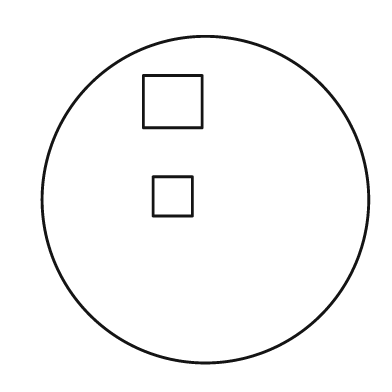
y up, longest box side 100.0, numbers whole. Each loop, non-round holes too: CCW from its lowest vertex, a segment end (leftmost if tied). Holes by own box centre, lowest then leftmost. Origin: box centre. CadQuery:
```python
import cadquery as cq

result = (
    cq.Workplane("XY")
    .moveTo(0.0, 0.0)
    .circle(50.0)
    .moveTo(-16.0, -5.0)
    .lineTo(-4.0, -5.0)
    .lineTo(-4.0, 7.0)
    .lineTo(-16.0, 7.0)
    .close()
    .moveTo(-19.0, 22.0)
    .lineTo(-1.0, 22.0)
    .lineTo(-1.0, 38.0)
    .lineTo(-19.0, 38.0)
    .close()
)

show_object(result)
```